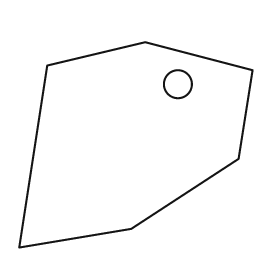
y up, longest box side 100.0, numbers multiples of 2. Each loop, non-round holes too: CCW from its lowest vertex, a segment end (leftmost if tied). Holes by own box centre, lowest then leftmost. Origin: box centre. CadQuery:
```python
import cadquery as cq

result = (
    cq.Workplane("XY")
    .moveTo(-50.0, -44.0)
    .lineTo(-2.0, -36.0)
    .lineTo(44.0, -6.0)
    .lineTo(50.0, 32.0)
    .lineTo(4.0, 44.0)
    .lineTo(-38.0, 34.0)
    .close()
    .moveTo(18.0, 26.0)
    .circle(6.0)
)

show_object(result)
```